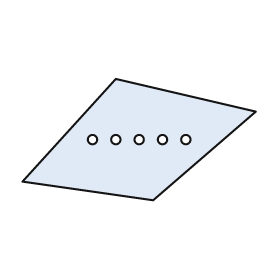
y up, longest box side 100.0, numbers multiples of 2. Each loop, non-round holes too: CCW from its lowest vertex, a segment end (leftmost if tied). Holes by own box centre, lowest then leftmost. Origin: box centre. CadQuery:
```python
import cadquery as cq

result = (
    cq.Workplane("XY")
    .moveTo(6.0, -26.0)
    .lineTo(50.0, 12.0)
    .lineTo(-10.0, 26.0)
    .lineTo(-50.0, -18.0)
    .close()
    .moveTo(-20.0, 0.0)
    .circle(2.0)
    .moveTo(-10.0, 0.0)
    .circle(2.0)
    .moveTo(0.0, 0.0)
    .circle(2.0)
    .moveTo(10.0, 0.0)
    .circle(2.0)
    .moveTo(20.0, 0.0)
    .circle(2.0)
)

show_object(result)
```